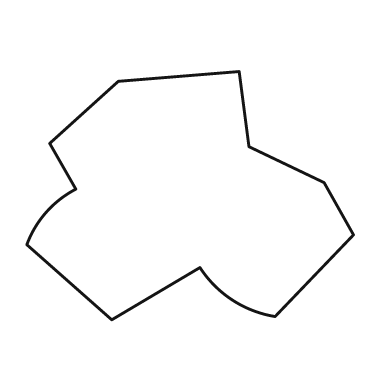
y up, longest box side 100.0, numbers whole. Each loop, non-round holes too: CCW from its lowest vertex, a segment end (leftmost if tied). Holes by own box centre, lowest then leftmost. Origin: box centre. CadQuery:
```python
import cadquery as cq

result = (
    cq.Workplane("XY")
    .moveTo(-24.0, -38.0)
    .lineTo(3.0, -22.0)
    .threePointArc((13.0, -32.0), (26.0, -37.0))
    .lineTo(50.0, -12.0)
    .lineTo(41.0, 4.0)
    .lineTo(18.0, 15.0)
    .lineTo(15.0, 38.0)
    .lineTo(-22.0, 35.0)
    .lineTo(-43.0, 16.0)
    .lineTo(-35.0, 2.0)
    .threePointArc((-44.0, -5.0), (-50.0, -15.0))
    .close()
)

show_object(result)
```